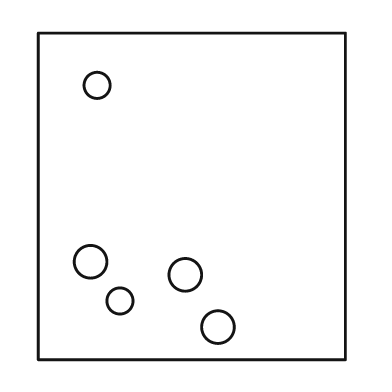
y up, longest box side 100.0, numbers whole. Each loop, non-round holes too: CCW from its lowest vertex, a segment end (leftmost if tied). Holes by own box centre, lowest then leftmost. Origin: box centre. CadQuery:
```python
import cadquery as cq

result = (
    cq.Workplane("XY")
    .moveTo(-47.0, -50.0)
    .lineTo(47.0, -50.0)
    .lineTo(47.0, 50.0)
    .lineTo(-47.0, 50.0)
    .close()
    .moveTo(8.0, -40.0)
    .circle(5.0)
    .moveTo(-22.0, -32.0)
    .circle(4.0)
    .moveTo(-2.0, -24.0)
    .circle(5.0)
    .moveTo(-31.0, -20.0)
    .circle(5.0)
    .moveTo(-29.0, 34.0)
    .circle(4.0)
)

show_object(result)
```